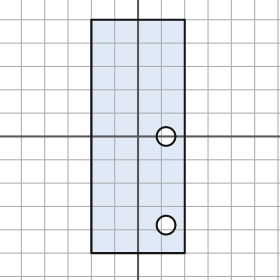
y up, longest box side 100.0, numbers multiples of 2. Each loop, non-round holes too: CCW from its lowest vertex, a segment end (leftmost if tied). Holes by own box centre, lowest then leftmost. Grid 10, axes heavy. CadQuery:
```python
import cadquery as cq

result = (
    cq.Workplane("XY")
    .moveTo(-20.0, -50.0)
    .lineTo(20.0, -50.0)
    .lineTo(20.0, 50.0)
    .lineTo(-20.0, 50.0)
    .close()
    .moveTo(12.0, -38.0)
    .circle(4.0)
    .moveTo(12.0, 0.0)
    .circle(4.0)
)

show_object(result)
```